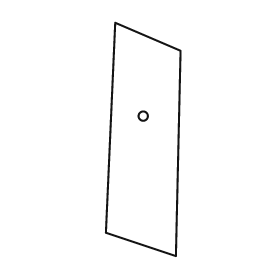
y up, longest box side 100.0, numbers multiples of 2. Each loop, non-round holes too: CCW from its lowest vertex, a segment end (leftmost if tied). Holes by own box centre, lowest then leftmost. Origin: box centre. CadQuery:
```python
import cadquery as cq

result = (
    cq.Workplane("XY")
    .moveTo(14.0, -50.0)
    .lineTo(16.0, 38.0)
    .lineTo(-12.0, 50.0)
    .lineTo(-16.0, -40.0)
    .close()
    .moveTo(0.0, 10.0)
    .circle(2.0)
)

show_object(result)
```